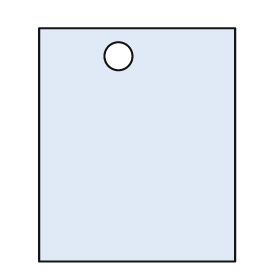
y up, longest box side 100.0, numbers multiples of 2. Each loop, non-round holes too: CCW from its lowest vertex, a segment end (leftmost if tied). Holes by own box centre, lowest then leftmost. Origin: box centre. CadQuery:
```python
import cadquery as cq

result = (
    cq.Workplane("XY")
    .moveTo(-42.0, -50.0)
    .lineTo(42.0, -50.0)
    .lineTo(42.0, 50.0)
    .lineTo(-42.0, 50.0)
    .close()
    .moveTo(-8.0, 38.0)
    .circle(6.0)
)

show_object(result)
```